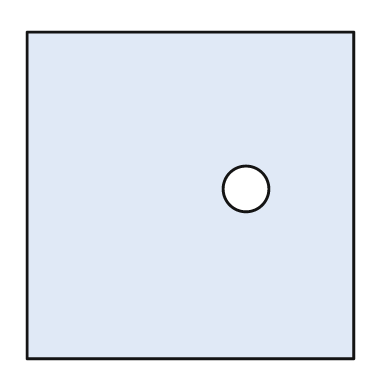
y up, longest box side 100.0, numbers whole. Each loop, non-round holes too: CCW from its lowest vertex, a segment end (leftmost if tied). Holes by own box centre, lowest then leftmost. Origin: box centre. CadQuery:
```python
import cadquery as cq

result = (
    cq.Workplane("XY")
    .moveTo(-50.0, -50.0)
    .lineTo(50.0, -50.0)
    .lineTo(50.0, 50.0)
    .lineTo(-50.0, 50.0)
    .close()
    .moveTo(17.0, 2.0)
    .circle(7.0)
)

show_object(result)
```